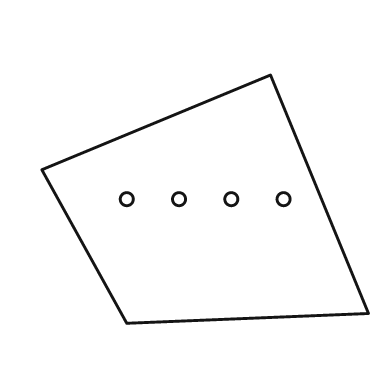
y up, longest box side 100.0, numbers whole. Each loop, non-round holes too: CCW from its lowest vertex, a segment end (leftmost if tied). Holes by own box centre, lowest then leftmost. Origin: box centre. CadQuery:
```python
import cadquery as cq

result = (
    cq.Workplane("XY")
    .moveTo(-24.0, -38.0)
    .lineTo(50.0, -35.0)
    .lineTo(20.0, 38.0)
    .lineTo(-50.0, 9.0)
    .close()
    .moveTo(-24.0, 0.0)
    .circle(2.0)
    .moveTo(-8.0, 0.0)
    .circle(2.0)
    .moveTo(8.0, 0.0)
    .circle(2.0)
    .moveTo(24.0, 0.0)
    .circle(2.0)
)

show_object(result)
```